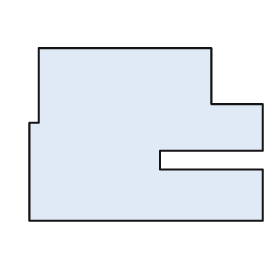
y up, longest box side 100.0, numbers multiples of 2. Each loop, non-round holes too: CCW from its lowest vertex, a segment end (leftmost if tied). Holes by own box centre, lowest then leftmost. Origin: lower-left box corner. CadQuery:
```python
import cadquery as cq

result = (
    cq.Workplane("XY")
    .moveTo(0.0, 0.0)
    .lineTo(100.0, 0.0)
    .lineTo(100.0, 22.0)
    .lineTo(56.0, 22.0)
    .lineTo(56.0, 30.0)
    .lineTo(100.0, 30.0)
    .lineTo(100.0, 50.0)
    .lineTo(78.0, 50.0)
    .lineTo(78.0, 74.0)
    .lineTo(4.0, 74.0)
    .lineTo(4.0, 42.0)
    .lineTo(0.0, 42.0)
    .close()
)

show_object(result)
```